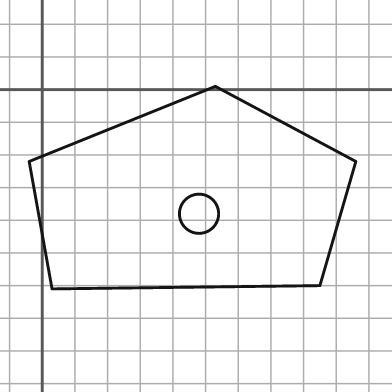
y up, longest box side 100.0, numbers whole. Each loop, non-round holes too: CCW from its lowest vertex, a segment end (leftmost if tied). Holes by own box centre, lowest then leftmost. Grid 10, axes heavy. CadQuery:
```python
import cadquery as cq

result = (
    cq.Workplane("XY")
    .moveTo(3.0, -61.0)
    .lineTo(85.0, -60.0)
    .lineTo(96.0, -22.0)
    .lineTo(53.0, 1.0)
    .lineTo(-4.0, -22.0)
    .close()
    .moveTo(48.0, -38.0)
    .circle(6.0)
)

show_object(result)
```